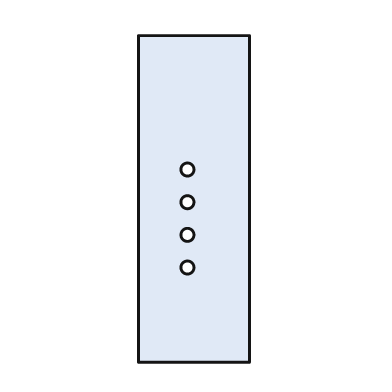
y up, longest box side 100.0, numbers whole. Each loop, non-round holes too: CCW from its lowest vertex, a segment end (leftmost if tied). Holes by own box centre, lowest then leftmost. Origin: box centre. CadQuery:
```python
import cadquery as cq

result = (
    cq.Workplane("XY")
    .moveTo(-17.0, -50.0)
    .lineTo(17.0, -50.0)
    .lineTo(17.0, 50.0)
    .lineTo(-17.0, 50.0)
    .close()
    .moveTo(-2.0, -21.0)
    .circle(2.0)
    .moveTo(-2.0, -11.0)
    .circle(2.0)
    .moveTo(-2.0, -1.0)
    .circle(2.0)
    .moveTo(-2.0, 9.0)
    .circle(2.0)
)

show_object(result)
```